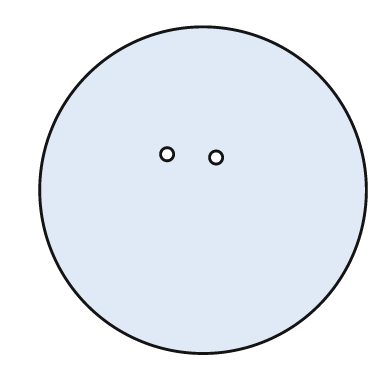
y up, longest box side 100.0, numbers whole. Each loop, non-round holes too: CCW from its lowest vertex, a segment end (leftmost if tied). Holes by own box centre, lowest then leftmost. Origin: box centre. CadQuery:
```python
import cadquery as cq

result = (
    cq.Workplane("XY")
    .moveTo(0.0, 0.0)
    .circle(50.0)
    .moveTo(4.0, 10.0)
    .circle(2.0)
    .moveTo(-11.0, 11.0)
    .circle(2.0)
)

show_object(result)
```